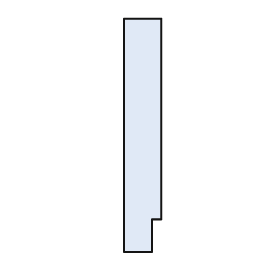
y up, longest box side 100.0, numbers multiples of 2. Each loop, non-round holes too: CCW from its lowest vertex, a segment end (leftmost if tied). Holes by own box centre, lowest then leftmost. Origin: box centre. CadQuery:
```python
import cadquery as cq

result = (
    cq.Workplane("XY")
    .moveTo(-8.0, -50.0)
    .lineTo(4.0, -50.0)
    .lineTo(4.0, -36.0)
    .lineTo(8.0, -36.0)
    .lineTo(8.0, 50.0)
    .lineTo(-8.0, 50.0)
    .close()
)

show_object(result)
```